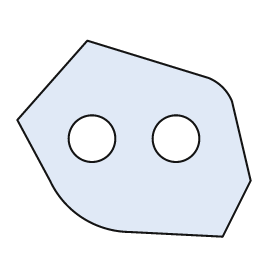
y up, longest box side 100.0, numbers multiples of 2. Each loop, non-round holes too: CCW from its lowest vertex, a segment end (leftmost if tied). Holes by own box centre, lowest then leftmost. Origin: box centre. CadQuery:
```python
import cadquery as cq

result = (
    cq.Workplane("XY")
    .moveTo(38.0, -42.0)
    .lineTo(50.0, -18.0)
    .lineTo(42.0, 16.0)
    .threePointArc((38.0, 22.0), (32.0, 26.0))
    .lineTo(-20.0, 42.0)
    .lineTo(-50.0, 8.0)
    .lineTo(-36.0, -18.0)
    .threePointArc((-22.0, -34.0), (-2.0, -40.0))
    .close()
    .moveTo(-18.0, 0.0)
    .circle(10.0)
    .moveTo(18.0, 0.0)
    .circle(10.0)
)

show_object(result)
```